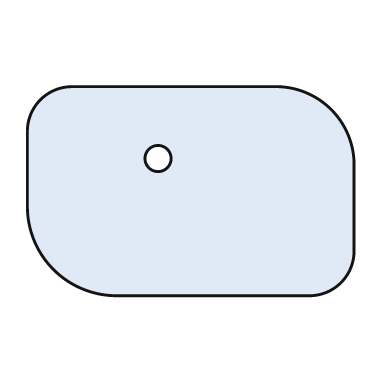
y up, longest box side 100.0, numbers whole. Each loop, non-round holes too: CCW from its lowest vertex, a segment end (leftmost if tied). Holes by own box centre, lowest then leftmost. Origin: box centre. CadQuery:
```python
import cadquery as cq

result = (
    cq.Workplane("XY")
    .moveTo(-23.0, -32.0)
    .lineTo(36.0, -32.0)
    .threePointArc((46.0, -28.0), (50.0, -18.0))
    .lineTo(50.0, 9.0)
    .threePointArc((43.0, 25.0), (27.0, 32.0))
    .lineTo(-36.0, 32.0)
    .threePointArc((-46.0, 28.0), (-50.0, 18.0))
    .lineTo(-50.0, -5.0)
    .threePointArc((-42.0, -24.0), (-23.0, -32.0))
    .close()
    .moveTo(-10.0, 10.0)
    .circle(4.0)
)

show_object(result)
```